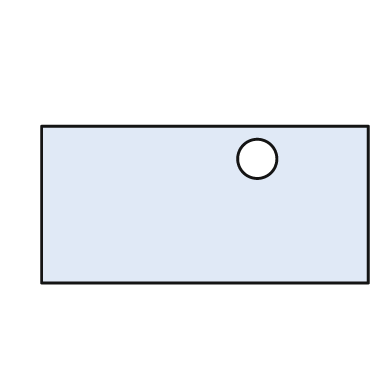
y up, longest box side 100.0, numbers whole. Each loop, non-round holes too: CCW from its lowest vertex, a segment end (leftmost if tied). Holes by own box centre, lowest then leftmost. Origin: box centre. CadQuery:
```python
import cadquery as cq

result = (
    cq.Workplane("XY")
    .moveTo(-50.0, -24.0)
    .lineTo(50.0, -24.0)
    .lineTo(50.0, 24.0)
    .lineTo(-50.0, 24.0)
    .close()
    .moveTo(16.0, 14.0)
    .circle(6.0)
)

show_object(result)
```